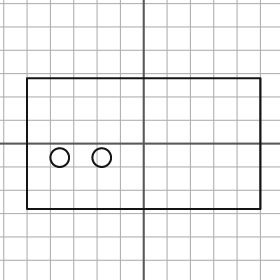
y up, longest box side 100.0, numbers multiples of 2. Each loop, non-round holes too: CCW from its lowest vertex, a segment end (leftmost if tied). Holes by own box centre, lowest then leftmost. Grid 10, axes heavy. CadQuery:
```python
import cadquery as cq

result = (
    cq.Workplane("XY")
    .moveTo(-50.0, -28.0)
    .lineTo(50.0, -28.0)
    .lineTo(50.0, 28.0)
    .lineTo(-50.0, 28.0)
    .close()
    .moveTo(-36.0, -6.0)
    .circle(4.0)
    .moveTo(-18.0, -6.0)
    .circle(4.0)
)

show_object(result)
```